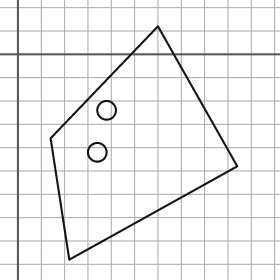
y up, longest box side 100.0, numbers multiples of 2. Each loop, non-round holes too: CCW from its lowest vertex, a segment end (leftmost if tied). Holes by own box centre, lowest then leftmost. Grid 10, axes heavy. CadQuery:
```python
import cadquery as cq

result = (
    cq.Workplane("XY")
    .moveTo(22.0, -88.0)
    .lineTo(94.0, -48.0)
    .lineTo(60.0, 12.0)
    .lineTo(14.0, -36.0)
    .close()
    .moveTo(34.0, -42.0)
    .circle(4.0)
    .moveTo(38.0, -24.0)
    .circle(4.0)
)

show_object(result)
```